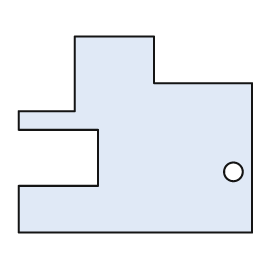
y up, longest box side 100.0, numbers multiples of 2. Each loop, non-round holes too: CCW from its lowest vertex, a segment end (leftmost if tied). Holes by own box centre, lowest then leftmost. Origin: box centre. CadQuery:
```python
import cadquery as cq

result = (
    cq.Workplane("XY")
    .moveTo(-50.0, -42.0)
    .lineTo(50.0, -42.0)
    .lineTo(50.0, 22.0)
    .lineTo(8.0, 22.0)
    .lineTo(8.0, 42.0)
    .lineTo(-26.0, 42.0)
    .lineTo(-26.0, 10.0)
    .lineTo(-50.0, 10.0)
    .lineTo(-50.0, 2.0)
    .lineTo(-16.0, 2.0)
    .lineTo(-16.0, -22.0)
    .lineTo(-50.0, -22.0)
    .close()
    .moveTo(42.0, -16.0)
    .circle(4.0)
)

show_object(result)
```